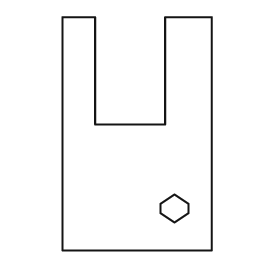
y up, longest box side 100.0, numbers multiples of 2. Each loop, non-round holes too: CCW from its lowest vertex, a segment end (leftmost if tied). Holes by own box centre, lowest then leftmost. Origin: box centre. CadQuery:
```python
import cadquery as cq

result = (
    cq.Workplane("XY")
    .moveTo(-32.0, -50.0)
    .lineTo(32.0, -50.0)
    .lineTo(32.0, 50.0)
    .lineTo(12.0, 50.0)
    .lineTo(12.0, 4.0)
    .lineTo(-18.0, 4.0)
    .lineTo(-18.0, 50.0)
    .lineTo(-32.0, 50.0)
    .close()
    .moveTo(16.0, -38.0)
    .lineTo(22.0, -34.0)
    .lineTo(22.0, -30.0)
    .lineTo(16.0, -26.0)
    .lineTo(10.0, -30.0)
    .lineTo(10.0, -34.0)
    .close()
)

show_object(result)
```